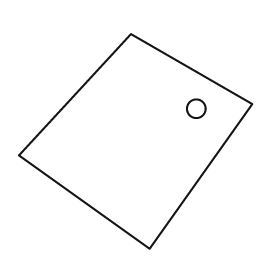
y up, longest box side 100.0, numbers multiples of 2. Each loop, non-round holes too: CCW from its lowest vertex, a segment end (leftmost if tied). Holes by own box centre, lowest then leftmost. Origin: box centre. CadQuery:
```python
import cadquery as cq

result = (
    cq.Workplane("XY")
    .moveTo(6.0, -46.0)
    .lineTo(50.0, 16.0)
    .lineTo(-2.0, 46.0)
    .lineTo(-50.0, -6.0)
    .close()
    .moveTo(26.0, 14.0)
    .circle(4.0)
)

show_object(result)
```